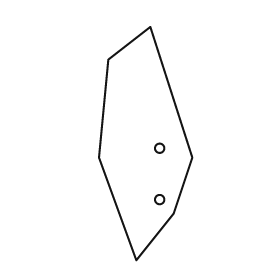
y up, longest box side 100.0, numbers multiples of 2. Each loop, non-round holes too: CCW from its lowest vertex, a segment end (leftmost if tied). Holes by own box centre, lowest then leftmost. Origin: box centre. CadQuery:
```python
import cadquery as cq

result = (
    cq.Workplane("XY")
    .moveTo(-4.0, -50.0)
    .lineTo(12.0, -30.0)
    .lineTo(20.0, -6.0)
    .lineTo(2.0, 50.0)
    .lineTo(-16.0, 36.0)
    .lineTo(-20.0, -6.0)
    .close()
    .moveTo(6.0, -24.0)
    .circle(2.0)
    .moveTo(6.0, -2.0)
    .circle(2.0)
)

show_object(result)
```